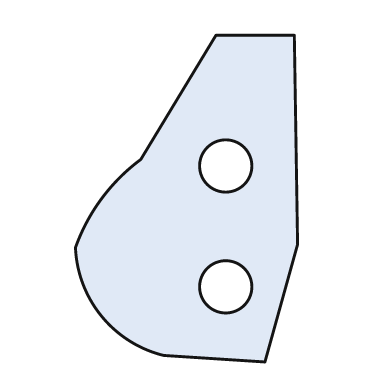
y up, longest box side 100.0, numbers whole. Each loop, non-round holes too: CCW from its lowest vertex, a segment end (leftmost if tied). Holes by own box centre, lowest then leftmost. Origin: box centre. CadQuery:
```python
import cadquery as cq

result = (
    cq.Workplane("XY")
    .moveTo(24.0, -50.0)
    .lineTo(34.0, -14.0)
    .lineTo(33.0, 50.0)
    .lineTo(9.0, 50.0)
    .lineTo(-14.0, 12.0)
    .threePointArc((-26.0, 0.0), (-34.0, -15.0))
    .threePointArc((-26.0, -36.0), (-7.0, -48.0))
    .close()
    .moveTo(12.0, -27.0)
    .circle(8.0)
    .moveTo(12.0, 10.0)
    .circle(8.0)
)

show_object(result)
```